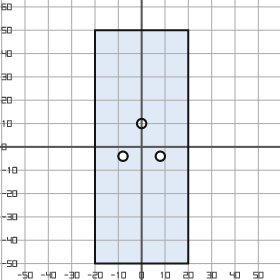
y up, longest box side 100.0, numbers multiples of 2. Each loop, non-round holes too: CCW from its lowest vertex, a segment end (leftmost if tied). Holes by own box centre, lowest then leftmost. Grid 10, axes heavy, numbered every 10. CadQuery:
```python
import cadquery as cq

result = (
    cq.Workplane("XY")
    .moveTo(-20.0, -50.0)
    .lineTo(20.0, -50.0)
    .lineTo(20.0, 50.0)
    .lineTo(-20.0, 50.0)
    .close()
    .moveTo(-8.0, -4.0)
    .circle(2.0)
    .moveTo(8.0, -4.0)
    .circle(2.0)
    .moveTo(0.0, 10.0)
    .circle(2.0)
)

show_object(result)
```